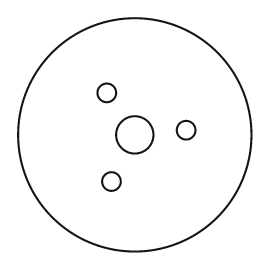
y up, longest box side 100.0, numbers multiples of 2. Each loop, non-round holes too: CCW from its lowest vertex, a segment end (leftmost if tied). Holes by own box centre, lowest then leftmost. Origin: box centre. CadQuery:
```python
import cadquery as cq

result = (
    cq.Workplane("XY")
    .moveTo(0.0, 0.0)
    .circle(50.0)
    .moveTo(-10.0, -20.0)
    .circle(4.0)
    .moveTo(0.0, 0.0)
    .circle(8.0)
    .moveTo(22.0, 2.0)
    .circle(4.0)
    .moveTo(-12.0, 18.0)
    .circle(4.0)
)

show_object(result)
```